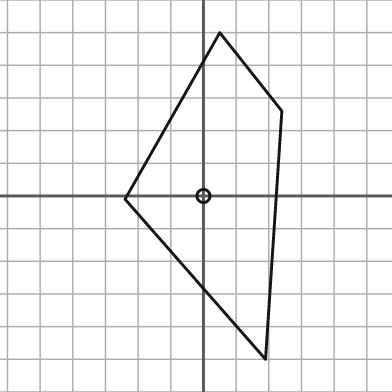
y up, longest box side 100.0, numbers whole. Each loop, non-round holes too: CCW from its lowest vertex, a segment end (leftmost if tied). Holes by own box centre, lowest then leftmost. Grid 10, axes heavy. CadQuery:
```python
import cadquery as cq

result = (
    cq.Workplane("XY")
    .moveTo(19.0, -50.0)
    .lineTo(24.0, 26.0)
    .lineTo(5.0, 50.0)
    .lineTo(-24.0, -1.0)
    .close()
    .moveTo(0.0, 0.0)
    .circle(2.0)
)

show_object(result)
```